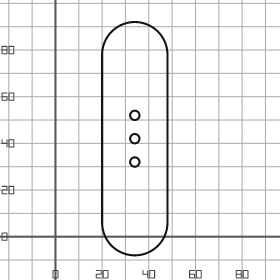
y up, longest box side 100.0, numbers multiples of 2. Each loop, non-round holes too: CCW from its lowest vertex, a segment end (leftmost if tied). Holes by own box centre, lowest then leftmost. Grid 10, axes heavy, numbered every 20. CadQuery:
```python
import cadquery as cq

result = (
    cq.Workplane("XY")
    .moveTo(20.0, 6.0)
    .threePointArc((34.0, -8.0), (48.0, 6.0))
    .lineTo(48.0, 78.0)
    .threePointArc((34.0, 92.0), (20.0, 78.0))
    .close()
    .moveTo(34.0, 32.0)
    .circle(2.0)
    .moveTo(34.0, 42.0)
    .circle(2.0)
    .moveTo(34.0, 52.0)
    .circle(2.0)
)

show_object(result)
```